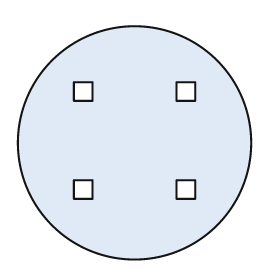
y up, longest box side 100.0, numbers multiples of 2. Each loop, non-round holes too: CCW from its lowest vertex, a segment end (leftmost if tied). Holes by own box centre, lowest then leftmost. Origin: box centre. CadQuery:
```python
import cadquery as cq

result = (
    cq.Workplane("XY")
    .moveTo(0.0, 0.0)
    .circle(50.0)
    .moveTo(-26.0, -24.0)
    .lineTo(-18.0, -24.0)
    .lineTo(-18.0, -16.0)
    .lineTo(-26.0, -16.0)
    .close()
    .moveTo(18.0, -24.0)
    .lineTo(26.0, -24.0)
    .lineTo(26.0, -16.0)
    .lineTo(18.0, -16.0)
    .close()
    .moveTo(-26.0, 18.0)
    .lineTo(-18.0, 18.0)
    .lineTo(-18.0, 26.0)
    .lineTo(-26.0, 26.0)
    .close()
    .moveTo(18.0, 18.0)
    .lineTo(26.0, 18.0)
    .lineTo(26.0, 26.0)
    .lineTo(18.0, 26.0)
    .close()
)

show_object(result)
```